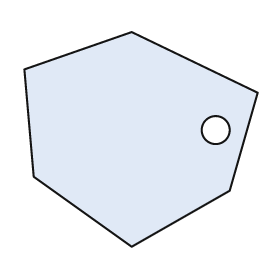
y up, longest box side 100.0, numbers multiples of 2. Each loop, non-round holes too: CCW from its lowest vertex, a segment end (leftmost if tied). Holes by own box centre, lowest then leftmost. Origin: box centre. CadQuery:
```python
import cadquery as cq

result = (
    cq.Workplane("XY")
    .moveTo(-4.0, -46.0)
    .lineTo(38.0, -22.0)
    .lineTo(50.0, 20.0)
    .lineTo(-4.0, 46.0)
    .lineTo(-50.0, 30.0)
    .lineTo(-46.0, -16.0)
    .close()
    .moveTo(32.0, 4.0)
    .circle(6.0)
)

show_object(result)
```